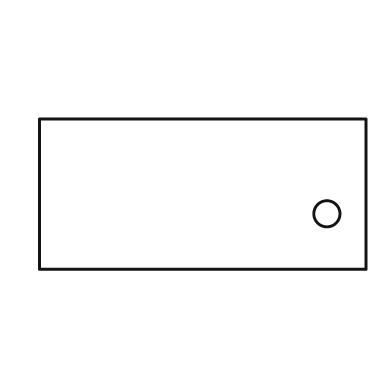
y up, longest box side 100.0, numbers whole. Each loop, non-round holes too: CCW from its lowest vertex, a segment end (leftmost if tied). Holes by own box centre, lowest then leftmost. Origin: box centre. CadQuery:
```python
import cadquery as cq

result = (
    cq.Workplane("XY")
    .moveTo(-50.0, -23.0)
    .lineTo(50.0, -23.0)
    .lineTo(50.0, 23.0)
    .lineTo(-50.0, 23.0)
    .close()
    .moveTo(38.0, -6.0)
    .circle(4.0)
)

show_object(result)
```